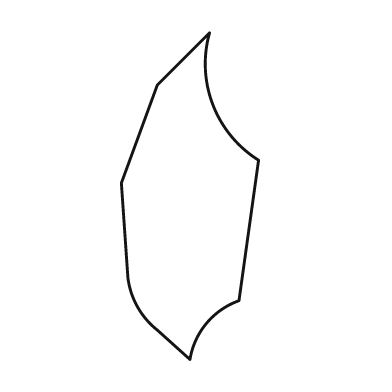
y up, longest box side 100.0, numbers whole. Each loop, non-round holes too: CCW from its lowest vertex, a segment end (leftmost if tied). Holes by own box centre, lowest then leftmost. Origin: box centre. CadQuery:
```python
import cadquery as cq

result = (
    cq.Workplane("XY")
    .moveTo(0.0, -50.0)
    .threePointArc((5.0, -39.0), (15.0, -32.0))
    .lineTo(21.0, 11.0)
    .threePointArc((7.0, 28.0), (6.0, 50.0))
    .lineTo(-10.0, 34.0)
    .lineTo(-21.0, 4.0)
    .lineTo(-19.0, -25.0)
    .threePointArc((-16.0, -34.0), (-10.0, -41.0))
    .close()
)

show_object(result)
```